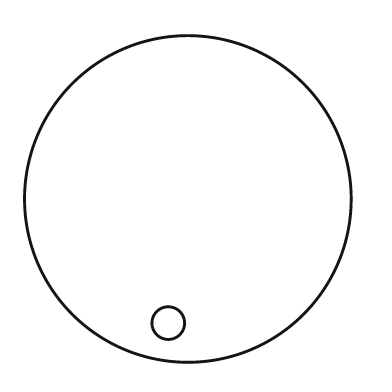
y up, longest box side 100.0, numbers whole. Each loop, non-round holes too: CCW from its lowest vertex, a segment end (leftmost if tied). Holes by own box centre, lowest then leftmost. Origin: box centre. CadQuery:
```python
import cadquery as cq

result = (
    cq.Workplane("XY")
    .moveTo(0.0, 0.0)
    .circle(50.0)
    .moveTo(-6.0, -38.0)
    .circle(5.0)
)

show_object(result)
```